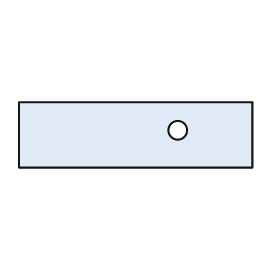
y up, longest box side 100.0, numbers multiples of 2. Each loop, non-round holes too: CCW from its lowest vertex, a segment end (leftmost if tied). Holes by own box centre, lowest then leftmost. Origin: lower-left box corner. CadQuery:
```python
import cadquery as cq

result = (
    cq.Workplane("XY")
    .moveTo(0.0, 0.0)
    .lineTo(100.0, 0.0)
    .lineTo(100.0, 28.0)
    .lineTo(0.0, 28.0)
    .close()
    .moveTo(68.0, 16.0)
    .circle(4.0)
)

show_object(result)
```